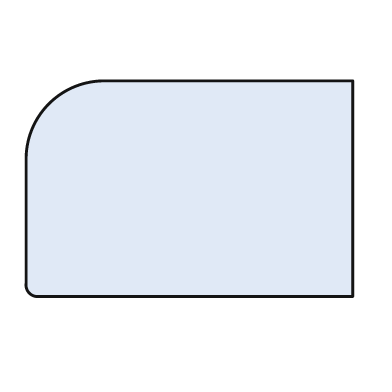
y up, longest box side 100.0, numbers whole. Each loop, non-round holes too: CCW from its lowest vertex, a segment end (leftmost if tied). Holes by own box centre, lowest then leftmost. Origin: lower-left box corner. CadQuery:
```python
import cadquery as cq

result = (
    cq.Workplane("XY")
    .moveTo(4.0, 0.0)
    .lineTo(100.0, 0.0)
    .lineTo(100.0, 66.0)
    .lineTo(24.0, 66.0)
    .threePointArc((7.0, 59.0), (0.0, 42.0))
    .lineTo(0.0, 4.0)
    .threePointArc((1.0, 1.0), (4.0, 0.0))
    .close()
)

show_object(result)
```